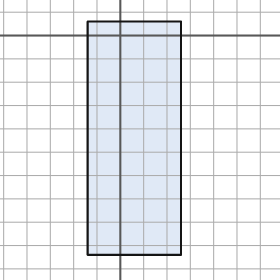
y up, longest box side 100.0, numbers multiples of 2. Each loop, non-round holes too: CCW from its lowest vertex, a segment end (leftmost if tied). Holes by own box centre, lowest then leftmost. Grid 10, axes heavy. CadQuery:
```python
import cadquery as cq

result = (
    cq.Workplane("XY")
    .moveTo(-14.0, -94.0)
    .lineTo(26.0, -94.0)
    .lineTo(26.0, 6.0)
    .lineTo(-14.0, 6.0)
    .close()
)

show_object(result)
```